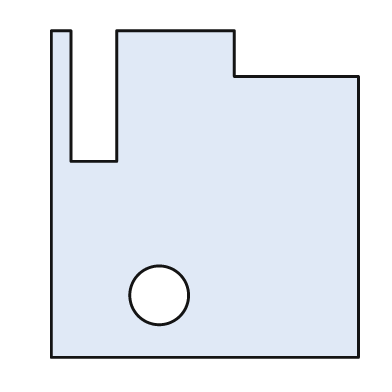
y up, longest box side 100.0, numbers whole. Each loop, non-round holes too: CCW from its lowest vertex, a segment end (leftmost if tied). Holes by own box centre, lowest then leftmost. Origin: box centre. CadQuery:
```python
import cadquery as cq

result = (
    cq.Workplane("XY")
    .moveTo(-47.0, -50.0)
    .lineTo(47.0, -50.0)
    .lineTo(47.0, 36.0)
    .lineTo(9.0, 36.0)
    .lineTo(9.0, 50.0)
    .lineTo(-27.0, 50.0)
    .lineTo(-27.0, 10.0)
    .lineTo(-41.0, 10.0)
    .lineTo(-41.0, 50.0)
    .lineTo(-47.0, 50.0)
    .close()
    .moveTo(-14.0, -31.0)
    .circle(9.0)
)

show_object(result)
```